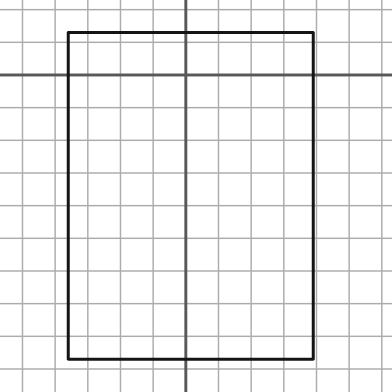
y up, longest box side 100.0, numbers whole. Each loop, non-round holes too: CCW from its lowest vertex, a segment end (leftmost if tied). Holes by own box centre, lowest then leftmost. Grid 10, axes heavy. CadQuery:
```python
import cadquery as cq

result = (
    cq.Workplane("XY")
    .moveTo(-36.0, -87.0)
    .lineTo(39.0, -87.0)
    .lineTo(39.0, 13.0)
    .lineTo(-36.0, 13.0)
    .close()
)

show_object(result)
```